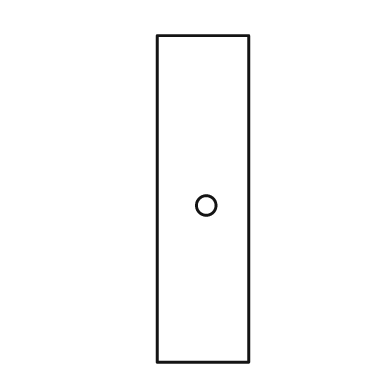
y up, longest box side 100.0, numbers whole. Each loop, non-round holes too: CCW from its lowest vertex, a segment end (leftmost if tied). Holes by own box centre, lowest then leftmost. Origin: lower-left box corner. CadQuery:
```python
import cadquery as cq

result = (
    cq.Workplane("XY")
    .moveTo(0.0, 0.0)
    .lineTo(28.0, 0.0)
    .lineTo(28.0, 100.0)
    .lineTo(0.0, 100.0)
    .close()
    .moveTo(15.0, 48.0)
    .circle(3.0)
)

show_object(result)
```